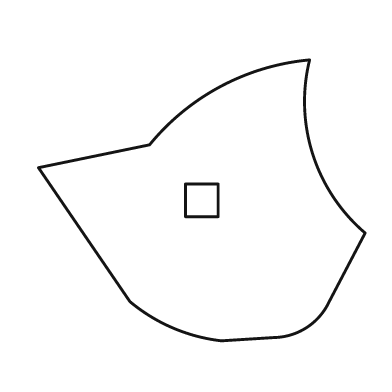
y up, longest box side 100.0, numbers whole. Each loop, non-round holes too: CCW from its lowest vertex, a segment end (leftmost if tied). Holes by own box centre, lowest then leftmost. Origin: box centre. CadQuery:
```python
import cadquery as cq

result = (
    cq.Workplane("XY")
    .moveTo(6.0, -43.0)
    .lineTo(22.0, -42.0)
    .threePointArc((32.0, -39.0), (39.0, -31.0))
    .lineTo(50.0, -10.0)
    .threePointArc((34.0, 14.0), (33.0, 43.0))
    .threePointArc((6.0, 35.0), (-16.0, 17.0))
    .lineTo(-50.0, 10.0)
    .lineTo(-22.0, -31.0)
    .threePointArc((-9.0, -39.0), (6.0, -43.0))
    .close()
    .moveTo(-5.0, -5.0)
    .lineTo(5.0, -5.0)
    .lineTo(5.0, 5.0)
    .lineTo(-5.0, 5.0)
    .close()
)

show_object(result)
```